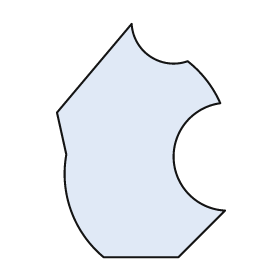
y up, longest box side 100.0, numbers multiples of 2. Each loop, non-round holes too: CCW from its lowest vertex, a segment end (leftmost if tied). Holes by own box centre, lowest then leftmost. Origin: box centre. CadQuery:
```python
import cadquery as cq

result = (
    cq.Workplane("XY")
    .moveTo(-16.0, -50.0)
    .lineTo(16.0, -50.0)
    .lineTo(36.0, -30.0)
    .threePointArc((14.0, -8.0), (34.0, 16.0))
    .threePointArc((28.0, 26.0), (20.0, 34.0))
    .threePointArc((4.0, 36.0), (-4.0, 50.0))
    .lineTo(-36.0, 12.0)
    .lineTo(-32.0, -6.0)
    .threePointArc((-30.0, -30.0), (-16.0, -50.0))
    .close()
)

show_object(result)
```